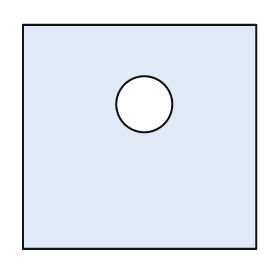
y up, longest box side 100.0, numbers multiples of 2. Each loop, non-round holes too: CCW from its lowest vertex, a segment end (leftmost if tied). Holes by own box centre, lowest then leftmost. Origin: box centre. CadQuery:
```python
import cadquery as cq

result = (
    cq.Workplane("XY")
    .moveTo(-50.0, -48.0)
    .lineTo(50.0, -48.0)
    .lineTo(50.0, 48.0)
    .lineTo(-50.0, 48.0)
    .close()
    .moveTo(2.0, 14.0)
    .circle(12.0)
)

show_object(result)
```